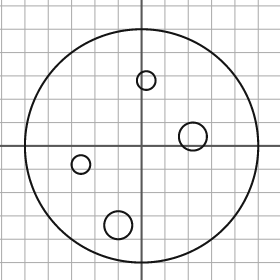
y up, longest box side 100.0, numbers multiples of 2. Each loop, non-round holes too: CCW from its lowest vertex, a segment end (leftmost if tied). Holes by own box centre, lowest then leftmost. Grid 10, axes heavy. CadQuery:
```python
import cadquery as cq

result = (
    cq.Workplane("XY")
    .moveTo(0.0, 0.0)
    .circle(50.0)
    .moveTo(-10.0, -34.0)
    .circle(6.0)
    .moveTo(-26.0, -8.0)
    .circle(4.0)
    .moveTo(22.0, 4.0)
    .circle(6.0)
    .moveTo(2.0, 28.0)
    .circle(4.0)
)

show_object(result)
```